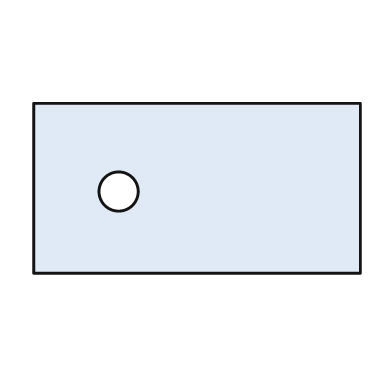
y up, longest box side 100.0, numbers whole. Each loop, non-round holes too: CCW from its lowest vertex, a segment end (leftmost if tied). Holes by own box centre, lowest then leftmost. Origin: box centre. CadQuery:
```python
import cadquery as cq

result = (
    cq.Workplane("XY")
    .moveTo(-50.0, -26.0)
    .lineTo(50.0, -26.0)
    .lineTo(50.0, 26.0)
    .lineTo(-50.0, 26.0)
    .close()
    .moveTo(-24.0, -1.0)
    .circle(6.0)
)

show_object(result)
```